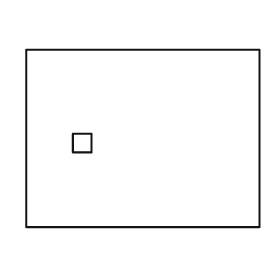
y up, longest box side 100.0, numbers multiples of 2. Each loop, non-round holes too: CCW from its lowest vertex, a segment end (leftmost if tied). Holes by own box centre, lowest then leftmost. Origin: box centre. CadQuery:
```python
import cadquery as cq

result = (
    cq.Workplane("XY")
    .moveTo(-50.0, -38.0)
    .lineTo(50.0, -38.0)
    .lineTo(50.0, 38.0)
    .lineTo(-50.0, 38.0)
    .close()
    .moveTo(-30.0, -6.0)
    .lineTo(-22.0, -6.0)
    .lineTo(-22.0, 2.0)
    .lineTo(-30.0, 2.0)
    .close()
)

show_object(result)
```